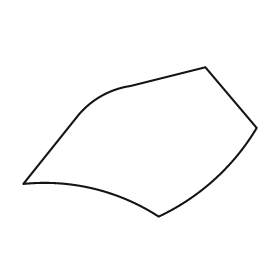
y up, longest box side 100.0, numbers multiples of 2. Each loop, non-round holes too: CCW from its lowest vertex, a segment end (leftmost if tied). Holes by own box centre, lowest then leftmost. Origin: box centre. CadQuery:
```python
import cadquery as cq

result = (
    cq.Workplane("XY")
    .moveTo(8.0, -32.0)
    .threePointArc((32.0, -16.0), (50.0, 6.0))
    .lineTo(28.0, 32.0)
    .lineTo(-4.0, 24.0)
    .threePointArc((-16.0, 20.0), (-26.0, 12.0))
    .lineTo(-50.0, -18.0)
    .threePointArc((-20.0, -20.0), (8.0, -32.0))
    .close()
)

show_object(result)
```